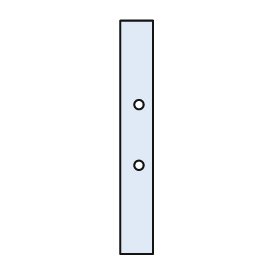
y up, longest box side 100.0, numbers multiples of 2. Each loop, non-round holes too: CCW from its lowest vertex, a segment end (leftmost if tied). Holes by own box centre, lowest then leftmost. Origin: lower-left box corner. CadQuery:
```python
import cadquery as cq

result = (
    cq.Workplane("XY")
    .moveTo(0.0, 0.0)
    .lineTo(14.0, 0.0)
    .lineTo(14.0, 100.0)
    .lineTo(0.0, 100.0)
    .close()
    .moveTo(8.0, 38.0)
    .circle(2.0)
    .moveTo(8.0, 64.0)
    .circle(2.0)
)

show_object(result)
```